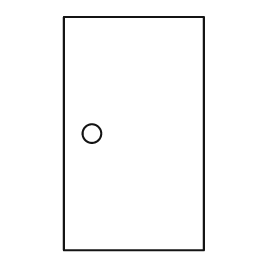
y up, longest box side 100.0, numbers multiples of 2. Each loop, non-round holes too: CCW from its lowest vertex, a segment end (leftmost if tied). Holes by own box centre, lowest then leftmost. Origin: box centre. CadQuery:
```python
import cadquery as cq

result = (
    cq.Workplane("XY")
    .moveTo(-30.0, -50.0)
    .lineTo(30.0, -50.0)
    .lineTo(30.0, 50.0)
    .lineTo(-30.0, 50.0)
    .close()
    .moveTo(-18.0, 0.0)
    .circle(4.0)
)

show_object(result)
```